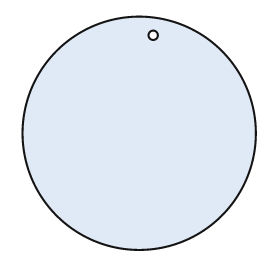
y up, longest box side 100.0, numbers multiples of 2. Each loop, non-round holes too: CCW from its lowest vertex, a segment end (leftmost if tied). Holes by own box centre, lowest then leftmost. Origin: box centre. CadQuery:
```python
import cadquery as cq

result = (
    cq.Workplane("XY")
    .moveTo(0.0, 0.0)
    .circle(50.0)
    .moveTo(6.0, 42.0)
    .circle(2.0)
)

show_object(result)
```